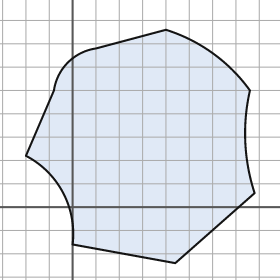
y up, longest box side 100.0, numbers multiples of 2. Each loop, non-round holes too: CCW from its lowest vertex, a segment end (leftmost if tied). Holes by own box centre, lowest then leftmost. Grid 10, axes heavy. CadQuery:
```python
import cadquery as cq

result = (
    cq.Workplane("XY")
    .moveTo(44.0, -24.0)
    .lineTo(78.0, 6.0)
    .threePointArc((74.0, 28.0), (76.0, 50.0))
    .threePointArc((60.0, 66.0), (40.0, 76.0))
    .lineTo(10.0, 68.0)
    .threePointArc((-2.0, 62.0), (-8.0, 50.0))
    .lineTo(-20.0, 22.0)
    .threePointArc((-4.0, 6.0), (0.0, -16.0))
    .close()
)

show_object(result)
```